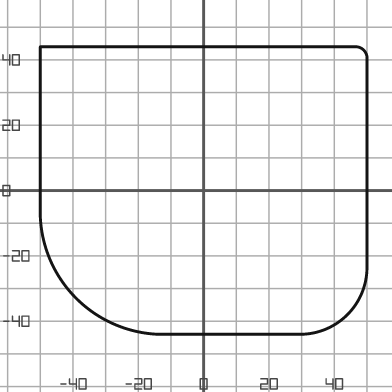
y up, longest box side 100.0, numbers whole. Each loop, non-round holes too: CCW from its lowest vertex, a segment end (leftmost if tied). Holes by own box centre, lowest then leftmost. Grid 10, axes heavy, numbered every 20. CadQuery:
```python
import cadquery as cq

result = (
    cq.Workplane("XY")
    .moveTo(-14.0, -44.0)
    .lineTo(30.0, -44.0)
    .threePointArc((44.0, -38.0), (50.0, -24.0))
    .lineTo(50.0, 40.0)
    .threePointArc((49.0, 43.0), (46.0, 44.0))
    .lineTo(-50.0, 44.0)
    .lineTo(-50.0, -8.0)
    .threePointArc((-39.0, -33.0), (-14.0, -44.0))
    .close()
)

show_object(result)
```